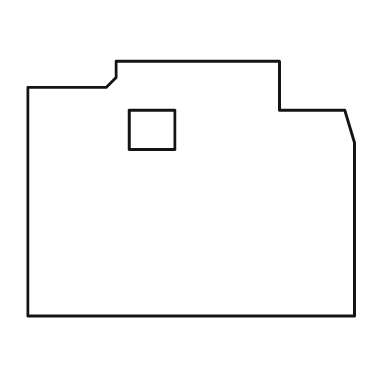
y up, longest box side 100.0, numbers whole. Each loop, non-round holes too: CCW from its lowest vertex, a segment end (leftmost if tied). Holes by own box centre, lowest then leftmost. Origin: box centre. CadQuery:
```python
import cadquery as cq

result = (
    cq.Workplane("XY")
    .moveTo(-50.0, -39.0)
    .lineTo(50.0, -39.0)
    .lineTo(50.0, 14.0)
    .lineTo(47.0, 24.0)
    .lineTo(27.0, 24.0)
    .lineTo(27.0, 39.0)
    .lineTo(-23.0, 39.0)
    .lineTo(-23.0, 34.0)
    .lineTo(-26.0, 31.0)
    .lineTo(-50.0, 31.0)
    .close()
    .moveTo(-19.0, 12.0)
    .lineTo(-5.0, 12.0)
    .lineTo(-5.0, 24.0)
    .lineTo(-19.0, 24.0)
    .close()
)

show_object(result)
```